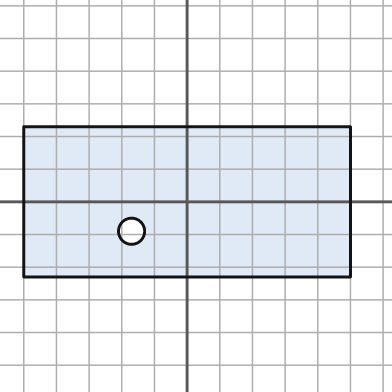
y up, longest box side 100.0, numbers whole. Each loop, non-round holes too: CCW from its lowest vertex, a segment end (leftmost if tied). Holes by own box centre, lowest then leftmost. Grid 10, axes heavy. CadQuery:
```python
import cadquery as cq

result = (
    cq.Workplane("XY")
    .moveTo(-50.0, -23.0)
    .lineTo(50.0, -23.0)
    .lineTo(50.0, 23.0)
    .lineTo(-50.0, 23.0)
    .close()
    .moveTo(-17.0, -9.0)
    .circle(4.0)
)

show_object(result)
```